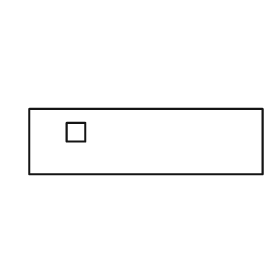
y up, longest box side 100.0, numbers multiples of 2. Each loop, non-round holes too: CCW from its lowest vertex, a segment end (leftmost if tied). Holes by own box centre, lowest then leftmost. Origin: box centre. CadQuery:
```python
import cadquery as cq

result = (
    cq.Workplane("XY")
    .moveTo(-50.0, -14.0)
    .lineTo(50.0, -14.0)
    .lineTo(50.0, 14.0)
    .lineTo(-50.0, 14.0)
    .close()
    .moveTo(-34.0, 0.0)
    .lineTo(-26.0, 0.0)
    .lineTo(-26.0, 8.0)
    .lineTo(-34.0, 8.0)
    .close()
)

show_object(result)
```